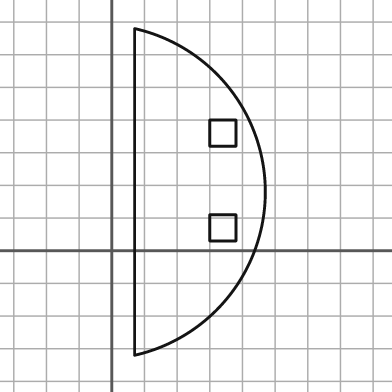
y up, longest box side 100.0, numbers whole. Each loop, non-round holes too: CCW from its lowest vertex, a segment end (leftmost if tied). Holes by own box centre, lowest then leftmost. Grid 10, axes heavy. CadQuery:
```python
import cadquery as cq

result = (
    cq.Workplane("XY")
    .moveTo(7.0, -32.0)
    .threePointArc((47.0, 18.0), (7.0, 68.0))
    .close()
    .moveTo(30.0, 3.0)
    .lineTo(38.0, 3.0)
    .lineTo(38.0, 11.0)
    .lineTo(30.0, 11.0)
    .close()
    .moveTo(30.0, 32.0)
    .lineTo(38.0, 32.0)
    .lineTo(38.0, 40.0)
    .lineTo(30.0, 40.0)
    .close()
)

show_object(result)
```